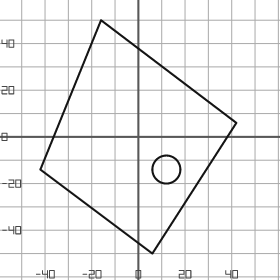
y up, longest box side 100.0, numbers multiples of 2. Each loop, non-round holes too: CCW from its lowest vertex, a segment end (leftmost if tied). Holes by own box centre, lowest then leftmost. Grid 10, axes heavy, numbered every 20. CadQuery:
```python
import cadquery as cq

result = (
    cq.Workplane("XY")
    .moveTo(6.0, -50.0)
    .lineTo(42.0, 6.0)
    .lineTo(-16.0, 50.0)
    .lineTo(-42.0, -14.0)
    .close()
    .moveTo(12.0, -14.0)
    .circle(6.0)
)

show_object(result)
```